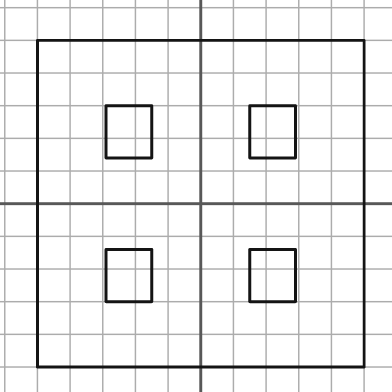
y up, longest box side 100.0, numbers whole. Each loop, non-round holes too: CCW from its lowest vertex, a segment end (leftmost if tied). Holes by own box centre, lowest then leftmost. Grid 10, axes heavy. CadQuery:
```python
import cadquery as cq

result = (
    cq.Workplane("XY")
    .moveTo(-50.0, -50.0)
    .lineTo(50.0, -50.0)
    .lineTo(50.0, 50.0)
    .lineTo(-50.0, 50.0)
    .close()
    .moveTo(-29.0, -30.0)
    .lineTo(-15.0, -30.0)
    .lineTo(-15.0, -14.0)
    .lineTo(-29.0, -14.0)
    .close()
    .moveTo(15.0, -30.0)
    .lineTo(29.0, -30.0)
    .lineTo(29.0, -14.0)
    .lineTo(15.0, -14.0)
    .close()
    .moveTo(-29.0, 14.0)
    .lineTo(-15.0, 14.0)
    .lineTo(-15.0, 30.0)
    .lineTo(-29.0, 30.0)
    .close()
    .moveTo(15.0, 14.0)
    .lineTo(29.0, 14.0)
    .lineTo(29.0, 30.0)
    .lineTo(15.0, 30.0)
    .close()
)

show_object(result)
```